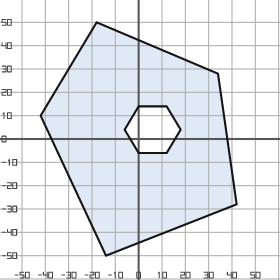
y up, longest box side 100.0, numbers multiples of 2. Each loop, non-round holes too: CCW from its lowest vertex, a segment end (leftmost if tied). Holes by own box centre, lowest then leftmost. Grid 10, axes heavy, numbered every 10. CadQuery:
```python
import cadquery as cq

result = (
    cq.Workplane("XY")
    .moveTo(-14.0, -50.0)
    .lineTo(42.0, -28.0)
    .lineTo(34.0, 28.0)
    .lineTo(-18.0, 50.0)
    .lineTo(-42.0, 10.0)
    .close()
    .moveTo(0.0, -6.0)
    .lineTo(12.0, -6.0)
    .lineTo(18.0, 4.0)
    .lineTo(12.0, 14.0)
    .lineTo(0.0, 14.0)
    .lineTo(-6.0, 4.0)
    .close()
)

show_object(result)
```